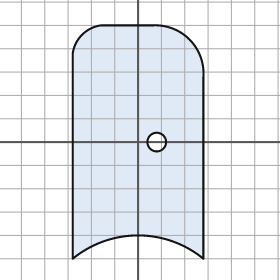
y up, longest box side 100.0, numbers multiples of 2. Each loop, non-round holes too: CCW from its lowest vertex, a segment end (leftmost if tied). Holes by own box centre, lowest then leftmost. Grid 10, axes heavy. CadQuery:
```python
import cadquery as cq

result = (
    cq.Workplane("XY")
    .moveTo(-28.0, -50.0)
    .threePointArc((0.0, -40.0), (28.0, -50.0))
    .lineTo(28.0, 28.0)
    .threePointArc((22.0, 44.0), (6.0, 50.0))
    .lineTo(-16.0, 50.0)
    .threePointArc((-24.0, 46.0), (-28.0, 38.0))
    .close()
    .moveTo(8.0, 0.0)
    .circle(4.0)
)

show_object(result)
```